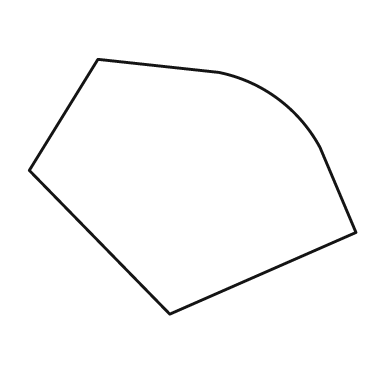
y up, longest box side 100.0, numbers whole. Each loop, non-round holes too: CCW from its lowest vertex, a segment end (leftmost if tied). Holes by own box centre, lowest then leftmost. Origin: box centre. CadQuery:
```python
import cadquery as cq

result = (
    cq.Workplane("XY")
    .moveTo(-7.0, -39.0)
    .lineTo(50.0, -14.0)
    .lineTo(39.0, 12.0)
    .threePointArc((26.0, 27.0), (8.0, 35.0))
    .lineTo(-29.0, 39.0)
    .lineTo(-50.0, 5.0)
    .close()
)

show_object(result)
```